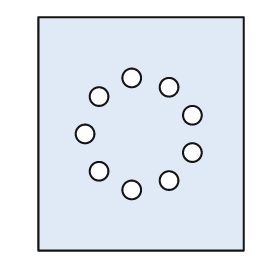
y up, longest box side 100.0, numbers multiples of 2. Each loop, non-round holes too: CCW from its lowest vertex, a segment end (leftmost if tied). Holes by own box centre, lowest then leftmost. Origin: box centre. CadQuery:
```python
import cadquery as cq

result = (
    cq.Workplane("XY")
    .moveTo(-44.0, -50.0)
    .lineTo(44.0, -50.0)
    .lineTo(44.0, 50.0)
    .lineTo(-44.0, 50.0)
    .close()
    .moveTo(-4.0, -24.0)
    .circle(4.0)
    .moveTo(12.0, -20.0)
    .circle(4.0)
    .moveTo(-18.0, -16.0)
    .circle(4.0)
    .moveTo(22.0, -8.0)
    .circle(4.0)
    .moveTo(-24.0, 0.0)
    .circle(4.0)
    .moveTo(22.0, 8.0)
    .circle(4.0)
    .moveTo(-18.0, 16.0)
    .circle(4.0)
    .moveTo(12.0, 20.0)
    .circle(4.0)
    .moveTo(-4.0, 24.0)
    .circle(4.0)
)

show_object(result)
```